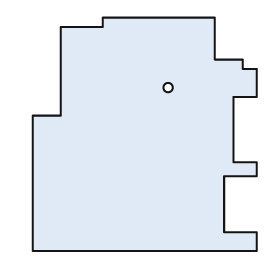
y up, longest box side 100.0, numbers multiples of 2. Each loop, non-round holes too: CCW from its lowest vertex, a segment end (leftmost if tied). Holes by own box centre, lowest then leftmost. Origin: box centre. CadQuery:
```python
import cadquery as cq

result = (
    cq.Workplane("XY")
    .moveTo(-48.0, -50.0)
    .lineTo(48.0, -50.0)
    .lineTo(48.0, -42.0)
    .lineTo(34.0, -42.0)
    .lineTo(34.0, -18.0)
    .lineTo(48.0, -18.0)
    .lineTo(48.0, -12.0)
    .lineTo(38.0, -12.0)
    .lineTo(38.0, 16.0)
    .lineTo(48.0, 16.0)
    .lineTo(48.0, 28.0)
    .lineTo(42.0, 28.0)
    .lineTo(42.0, 32.0)
    .lineTo(30.0, 32.0)
    .lineTo(30.0, 50.0)
    .lineTo(-18.0, 50.0)
    .lineTo(-18.0, 46.0)
    .lineTo(-36.0, 46.0)
    .lineTo(-36.0, 8.0)
    .lineTo(-48.0, 8.0)
    .close()
    .moveTo(10.0, 20.0)
    .circle(2.0)
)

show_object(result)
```